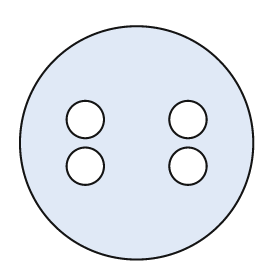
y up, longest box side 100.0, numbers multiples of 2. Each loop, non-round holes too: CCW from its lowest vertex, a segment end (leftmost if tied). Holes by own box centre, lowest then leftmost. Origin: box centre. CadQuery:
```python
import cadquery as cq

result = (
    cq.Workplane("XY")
    .moveTo(0.0, 0.0)
    .circle(50.0)
    .moveTo(-22.0, -10.0)
    .circle(8.0)
    .moveTo(22.0, -10.0)
    .circle(8.0)
    .moveTo(-22.0, 10.0)
    .circle(8.0)
    .moveTo(22.0, 10.0)
    .circle(8.0)
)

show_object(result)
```